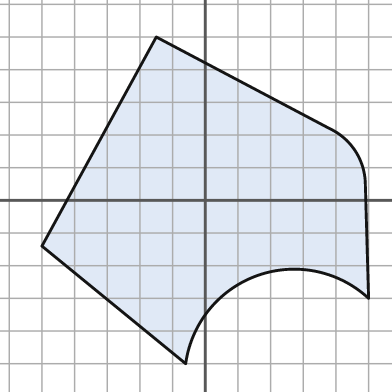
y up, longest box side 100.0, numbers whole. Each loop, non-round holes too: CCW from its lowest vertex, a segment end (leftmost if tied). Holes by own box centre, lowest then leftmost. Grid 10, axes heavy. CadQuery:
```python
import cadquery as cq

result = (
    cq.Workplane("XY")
    .moveTo(-6.0, -50.0)
    .threePointArc((16.0, -23.0), (50.0, -30.0))
    .lineTo(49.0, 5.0)
    .threePointArc((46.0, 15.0), (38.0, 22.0))
    .lineTo(-15.0, 50.0)
    .lineTo(-50.0, -14.0)
    .close()
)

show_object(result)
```